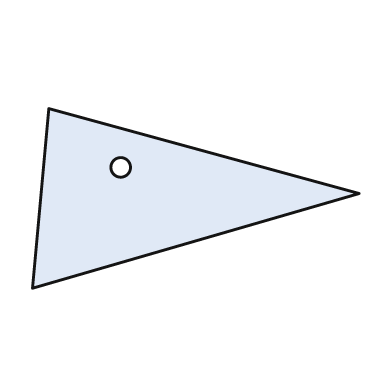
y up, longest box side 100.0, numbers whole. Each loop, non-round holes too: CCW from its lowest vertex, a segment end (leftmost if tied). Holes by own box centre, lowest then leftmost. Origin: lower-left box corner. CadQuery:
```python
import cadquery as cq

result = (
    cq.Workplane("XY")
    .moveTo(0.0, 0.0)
    .lineTo(100.0, 29.0)
    .lineTo(5.0, 55.0)
    .close()
    .moveTo(27.0, 37.0)
    .circle(3.0)
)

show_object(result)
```